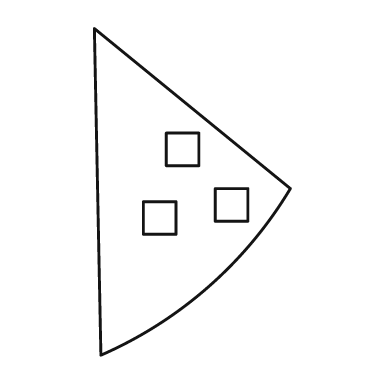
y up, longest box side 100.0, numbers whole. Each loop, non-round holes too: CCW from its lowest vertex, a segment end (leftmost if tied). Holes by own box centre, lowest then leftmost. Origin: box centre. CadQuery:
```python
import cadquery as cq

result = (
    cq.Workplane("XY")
    .moveTo(-28.0, -50.0)
    .threePointArc((5.0, -29.0), (30.0, 1.0))
    .lineTo(-30.0, 50.0)
    .close()
    .moveTo(-15.0, -13.0)
    .lineTo(-5.0, -13.0)
    .lineTo(-5.0, -3.0)
    .lineTo(-15.0, -3.0)
    .close()
    .moveTo(7.0, -9.0)
    .lineTo(17.0, -9.0)
    .lineTo(17.0, 1.0)
    .lineTo(7.0, 1.0)
    .close()
    .moveTo(-8.0, 8.0)
    .lineTo(2.0, 8.0)
    .lineTo(2.0, 18.0)
    .lineTo(-8.0, 18.0)
    .close()
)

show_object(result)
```